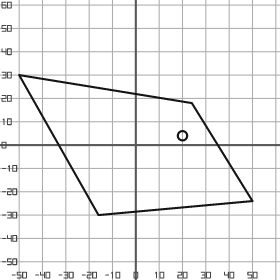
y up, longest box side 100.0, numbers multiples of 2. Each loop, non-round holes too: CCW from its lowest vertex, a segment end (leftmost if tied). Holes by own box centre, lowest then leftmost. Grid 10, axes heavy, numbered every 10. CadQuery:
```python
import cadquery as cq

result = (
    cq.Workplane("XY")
    .moveTo(-16.0, -30.0)
    .lineTo(50.0, -24.0)
    .lineTo(24.0, 18.0)
    .lineTo(-50.0, 30.0)
    .close()
    .moveTo(20.0, 4.0)
    .circle(2.0)
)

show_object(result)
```